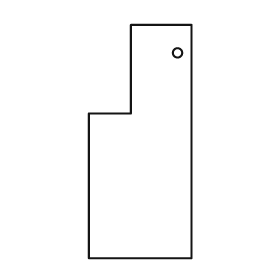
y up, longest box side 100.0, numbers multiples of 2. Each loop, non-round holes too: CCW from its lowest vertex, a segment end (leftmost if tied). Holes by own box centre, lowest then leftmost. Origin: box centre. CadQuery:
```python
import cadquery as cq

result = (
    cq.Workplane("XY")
    .moveTo(-22.0, -50.0)
    .lineTo(22.0, -50.0)
    .lineTo(22.0, 50.0)
    .lineTo(-4.0, 50.0)
    .lineTo(-4.0, 12.0)
    .lineTo(-22.0, 12.0)
    .close()
    .moveTo(16.0, 38.0)
    .circle(2.0)
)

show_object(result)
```